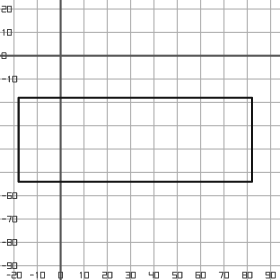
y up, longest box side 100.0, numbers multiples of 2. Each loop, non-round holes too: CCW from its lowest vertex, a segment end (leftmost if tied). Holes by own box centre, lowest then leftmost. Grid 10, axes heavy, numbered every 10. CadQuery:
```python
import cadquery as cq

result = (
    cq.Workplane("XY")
    .moveTo(-18.0, -54.0)
    .lineTo(82.0, -54.0)
    .lineTo(82.0, -18.0)
    .lineTo(-18.0, -18.0)
    .close()
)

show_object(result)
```